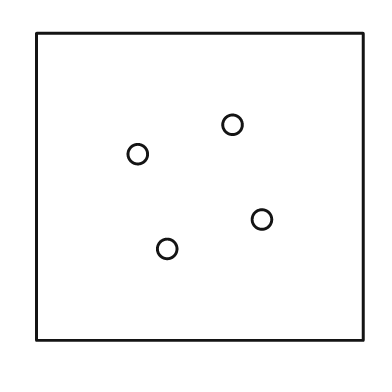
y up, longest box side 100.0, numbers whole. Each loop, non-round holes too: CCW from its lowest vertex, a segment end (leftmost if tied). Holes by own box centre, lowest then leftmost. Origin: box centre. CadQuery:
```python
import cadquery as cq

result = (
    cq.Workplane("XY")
    .moveTo(-50.0, -47.0)
    .lineTo(50.0, -47.0)
    .lineTo(50.0, 47.0)
    .lineTo(-50.0, 47.0)
    .close()
    .moveTo(-10.0, -19.0)
    .circle(3.0)
    .moveTo(19.0, -10.0)
    .circle(3.0)
    .moveTo(-19.0, 10.0)
    .circle(3.0)
    .moveTo(10.0, 19.0)
    .circle(3.0)
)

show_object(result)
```